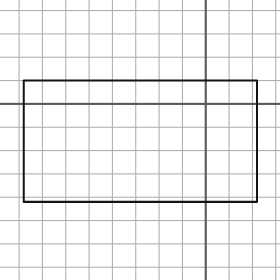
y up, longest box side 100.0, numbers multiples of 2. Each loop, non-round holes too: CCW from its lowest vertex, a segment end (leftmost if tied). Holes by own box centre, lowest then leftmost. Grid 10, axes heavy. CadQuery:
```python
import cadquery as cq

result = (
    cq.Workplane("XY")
    .moveTo(-78.0, -42.0)
    .lineTo(22.0, -42.0)
    .lineTo(22.0, 10.0)
    .lineTo(-78.0, 10.0)
    .close()
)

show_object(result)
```